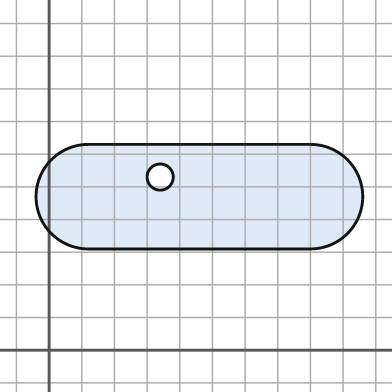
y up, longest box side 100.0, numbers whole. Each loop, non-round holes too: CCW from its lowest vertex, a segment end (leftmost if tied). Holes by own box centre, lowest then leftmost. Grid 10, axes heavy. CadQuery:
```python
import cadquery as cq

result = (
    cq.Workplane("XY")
    .moveTo(12.0, 31.0)
    .lineTo(80.0, 31.0)
    .threePointArc((96.0, 47.0), (80.0, 63.0))
    .lineTo(12.0, 63.0)
    .threePointArc((-4.0, 47.0), (12.0, 31.0))
    .close()
    .moveTo(34.0, 53.0)
    .circle(4.0)
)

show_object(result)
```